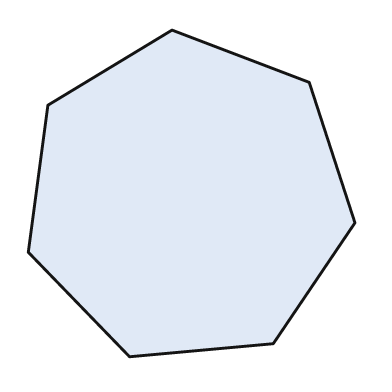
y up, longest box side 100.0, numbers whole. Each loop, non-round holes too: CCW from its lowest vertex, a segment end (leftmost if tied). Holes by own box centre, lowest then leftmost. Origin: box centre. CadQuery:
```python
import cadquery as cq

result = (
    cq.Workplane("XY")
    .moveTo(-19.0, -50.0)
    .lineTo(25.0, -46.0)
    .lineTo(50.0, -9.0)
    .lineTo(36.0, 34.0)
    .lineTo(-6.0, 50.0)
    .lineTo(-44.0, 27.0)
    .lineTo(-50.0, -18.0)
    .close()
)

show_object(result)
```